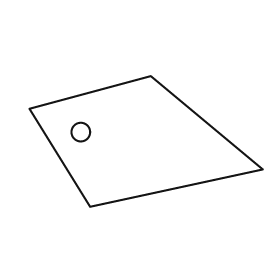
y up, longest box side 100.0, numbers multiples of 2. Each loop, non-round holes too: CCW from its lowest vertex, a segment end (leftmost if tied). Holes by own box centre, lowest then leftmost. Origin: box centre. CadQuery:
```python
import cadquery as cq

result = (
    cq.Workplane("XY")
    .moveTo(-24.0, -28.0)
    .lineTo(50.0, -12.0)
    .lineTo(2.0, 28.0)
    .lineTo(-50.0, 14.0)
    .close()
    .moveTo(-28.0, 4.0)
    .circle(4.0)
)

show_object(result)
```